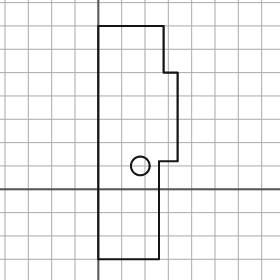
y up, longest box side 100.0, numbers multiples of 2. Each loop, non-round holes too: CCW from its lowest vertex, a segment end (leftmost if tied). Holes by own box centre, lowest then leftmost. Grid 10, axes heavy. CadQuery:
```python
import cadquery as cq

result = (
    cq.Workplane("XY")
    .moveTo(0.0, -30.0)
    .lineTo(26.0, -30.0)
    .lineTo(26.0, 12.0)
    .lineTo(34.0, 12.0)
    .lineTo(34.0, 50.0)
    .lineTo(28.0, 50.0)
    .lineTo(28.0, 70.0)
    .lineTo(0.0, 70.0)
    .close()
    .moveTo(18.0, 10.0)
    .circle(4.0)
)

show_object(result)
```